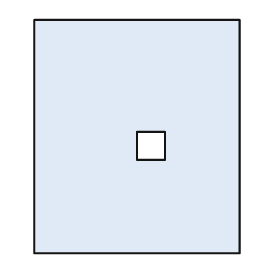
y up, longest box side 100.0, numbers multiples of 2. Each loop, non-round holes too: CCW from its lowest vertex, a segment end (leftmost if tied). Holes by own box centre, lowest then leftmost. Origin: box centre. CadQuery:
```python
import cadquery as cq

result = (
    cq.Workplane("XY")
    .moveTo(-44.0, -50.0)
    .lineTo(44.0, -50.0)
    .lineTo(44.0, 50.0)
    .lineTo(-44.0, 50.0)
    .close()
    .moveTo(0.0, -10.0)
    .lineTo(12.0, -10.0)
    .lineTo(12.0, 2.0)
    .lineTo(0.0, 2.0)
    .close()
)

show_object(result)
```